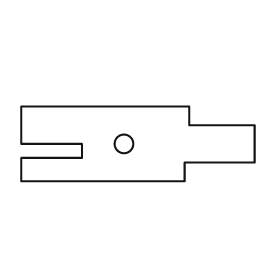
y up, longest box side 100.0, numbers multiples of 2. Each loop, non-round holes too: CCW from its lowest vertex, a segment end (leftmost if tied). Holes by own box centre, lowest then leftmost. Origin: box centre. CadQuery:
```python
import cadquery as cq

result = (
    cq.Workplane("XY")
    .moveTo(-50.0, -16.0)
    .lineTo(20.0, -16.0)
    .lineTo(20.0, -8.0)
    .lineTo(50.0, -8.0)
    .lineTo(50.0, 8.0)
    .lineTo(22.0, 8.0)
    .lineTo(22.0, 16.0)
    .lineTo(-50.0, 16.0)
    .lineTo(-50.0, 0.0)
    .lineTo(-24.0, 0.0)
    .lineTo(-24.0, -6.0)
    .lineTo(-50.0, -6.0)
    .close()
    .moveTo(-6.0, 0.0)
    .circle(4.0)
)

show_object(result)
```